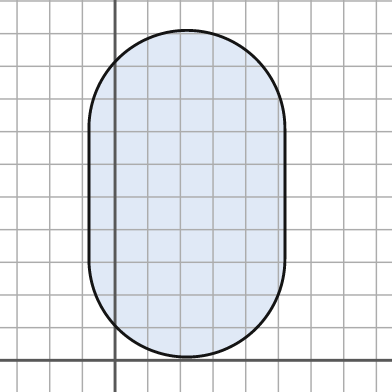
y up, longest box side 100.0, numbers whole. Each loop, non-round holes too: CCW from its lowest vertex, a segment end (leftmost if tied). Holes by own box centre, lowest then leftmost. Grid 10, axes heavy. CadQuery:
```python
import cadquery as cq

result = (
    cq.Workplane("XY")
    .moveTo(-8.0, 31.0)
    .threePointArc((22.0, 1.0), (52.0, 31.0))
    .lineTo(52.0, 71.0)
    .threePointArc((22.0, 101.0), (-8.0, 71.0))
    .close()
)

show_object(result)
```